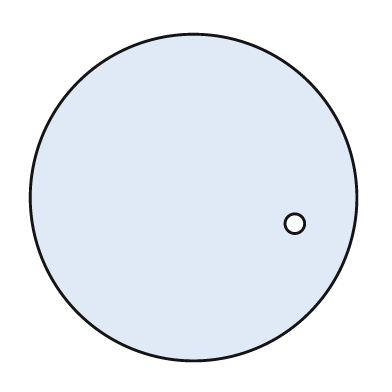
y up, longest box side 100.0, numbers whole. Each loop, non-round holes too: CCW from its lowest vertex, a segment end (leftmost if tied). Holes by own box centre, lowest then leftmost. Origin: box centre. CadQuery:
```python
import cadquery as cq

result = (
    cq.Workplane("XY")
    .moveTo(0.0, 0.0)
    .circle(50.0)
    .moveTo(31.0, -8.0)
    .circle(3.0)
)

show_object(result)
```